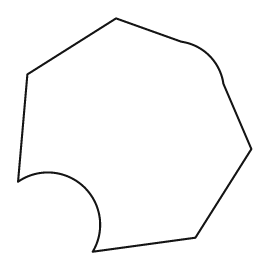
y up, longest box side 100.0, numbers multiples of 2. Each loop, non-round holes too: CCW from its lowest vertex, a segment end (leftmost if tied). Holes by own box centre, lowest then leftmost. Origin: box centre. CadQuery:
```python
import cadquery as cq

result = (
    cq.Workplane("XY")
    .moveTo(-18.0, -50.0)
    .lineTo(26.0, -44.0)
    .lineTo(50.0, -6.0)
    .lineTo(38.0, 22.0)
    .threePointArc((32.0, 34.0), (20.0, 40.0))
    .lineTo(-8.0, 50.0)
    .lineTo(-46.0, 26.0)
    .lineTo(-50.0, -20.0)
    .threePointArc((-22.0, -22.0), (-18.0, -50.0))
    .close()
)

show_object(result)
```